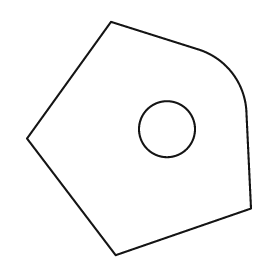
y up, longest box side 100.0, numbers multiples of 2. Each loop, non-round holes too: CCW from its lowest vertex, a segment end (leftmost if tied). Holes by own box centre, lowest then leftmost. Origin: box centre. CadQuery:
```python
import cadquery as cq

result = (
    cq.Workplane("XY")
    .moveTo(-10.0, -50.0)
    .lineTo(48.0, -30.0)
    .lineTo(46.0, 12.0)
    .threePointArc((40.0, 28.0), (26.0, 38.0))
    .lineTo(-12.0, 50.0)
    .lineTo(-48.0, 0.0)
    .close()
    .moveTo(12.0, 4.0)
    .circle(12.0)
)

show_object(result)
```